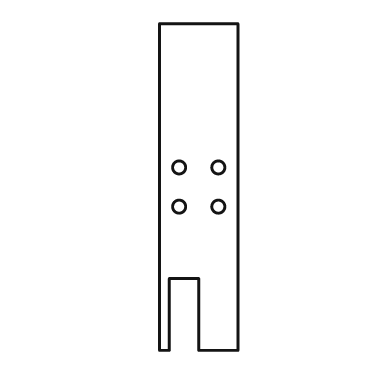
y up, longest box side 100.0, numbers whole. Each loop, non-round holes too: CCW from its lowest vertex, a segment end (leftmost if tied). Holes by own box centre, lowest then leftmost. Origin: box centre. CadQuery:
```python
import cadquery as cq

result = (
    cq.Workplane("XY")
    .moveTo(-12.0, -50.0)
    .lineTo(-9.0, -50.0)
    .lineTo(-9.0, -28.0)
    .lineTo(0.0, -28.0)
    .lineTo(0.0, -50.0)
    .lineTo(12.0, -50.0)
    .lineTo(12.0, 50.0)
    .lineTo(-12.0, 50.0)
    .close()
    .moveTo(-6.0, -6.0)
    .circle(2.0)
    .moveTo(6.0, -6.0)
    .circle(2.0)
    .moveTo(-6.0, 6.0)
    .circle(2.0)
    .moveTo(6.0, 6.0)
    .circle(2.0)
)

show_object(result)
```